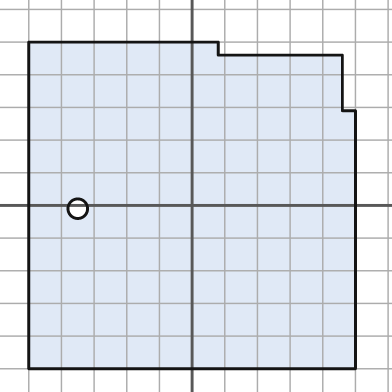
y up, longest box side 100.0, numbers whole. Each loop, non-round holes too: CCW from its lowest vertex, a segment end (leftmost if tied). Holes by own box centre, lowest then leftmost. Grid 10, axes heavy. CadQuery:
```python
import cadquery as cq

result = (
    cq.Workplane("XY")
    .moveTo(-50.0, -50.0)
    .lineTo(50.0, -50.0)
    .lineTo(50.0, 29.0)
    .lineTo(46.0, 29.0)
    .lineTo(46.0, 46.0)
    .lineTo(8.0, 46.0)
    .lineTo(8.0, 50.0)
    .lineTo(-50.0, 50.0)
    .close()
    .moveTo(-35.0, -1.0)
    .circle(3.0)
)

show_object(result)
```